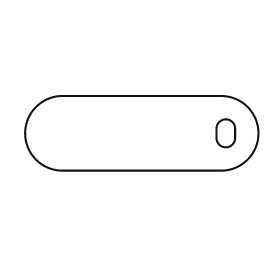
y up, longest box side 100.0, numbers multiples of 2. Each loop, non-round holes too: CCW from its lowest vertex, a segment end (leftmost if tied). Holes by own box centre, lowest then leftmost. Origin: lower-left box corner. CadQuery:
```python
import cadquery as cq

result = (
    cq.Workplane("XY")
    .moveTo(16.0, 0.0)
    .lineTo(84.0, 0.0)
    .threePointArc((100.0, 16.0), (84.0, 32.0))
    .lineTo(16.0, 32.0)
    .threePointArc((0.0, 16.0), (16.0, 0.0))
    .close()
    .moveTo(82.0, 14.0)
    .threePointArc((86.0, 10.0), (90.0, 14.0))
    .lineTo(90.0, 18.0)
    .threePointArc((86.0, 22.0), (82.0, 18.0))
    .close()
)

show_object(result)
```